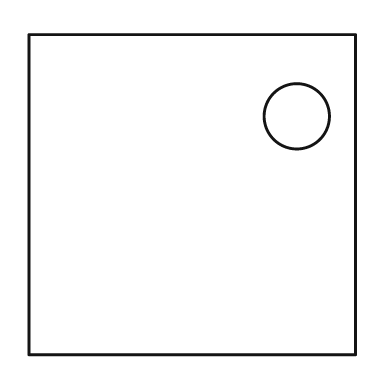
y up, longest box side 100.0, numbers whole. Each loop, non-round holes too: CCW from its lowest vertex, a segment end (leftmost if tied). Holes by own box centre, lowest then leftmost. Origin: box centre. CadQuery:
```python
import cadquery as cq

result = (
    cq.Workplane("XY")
    .moveTo(-50.0, -49.0)
    .lineTo(50.0, -49.0)
    .lineTo(50.0, 49.0)
    .lineTo(-50.0, 49.0)
    .close()
    .moveTo(32.0, 24.0)
    .circle(10.0)
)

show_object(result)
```